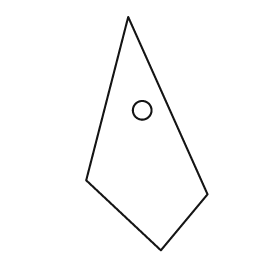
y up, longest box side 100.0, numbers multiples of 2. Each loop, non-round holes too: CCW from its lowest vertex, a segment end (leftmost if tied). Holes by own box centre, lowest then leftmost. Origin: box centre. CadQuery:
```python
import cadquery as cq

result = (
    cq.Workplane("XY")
    .moveTo(6.0, -50.0)
    .lineTo(26.0, -26.0)
    .lineTo(-8.0, 50.0)
    .lineTo(-26.0, -20.0)
    .close()
    .moveTo(-2.0, 10.0)
    .circle(4.0)
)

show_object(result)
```